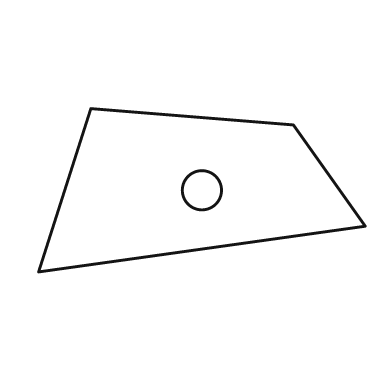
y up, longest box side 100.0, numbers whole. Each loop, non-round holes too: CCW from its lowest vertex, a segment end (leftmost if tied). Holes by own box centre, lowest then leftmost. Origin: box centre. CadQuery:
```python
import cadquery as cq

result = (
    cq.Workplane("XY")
    .moveTo(-50.0, -25.0)
    .lineTo(50.0, -11.0)
    .lineTo(28.0, 20.0)
    .lineTo(-34.0, 25.0)
    .close()
    .moveTo(0.0, 0.0)
    .circle(6.0)
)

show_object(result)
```